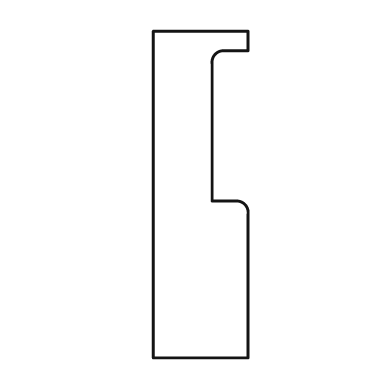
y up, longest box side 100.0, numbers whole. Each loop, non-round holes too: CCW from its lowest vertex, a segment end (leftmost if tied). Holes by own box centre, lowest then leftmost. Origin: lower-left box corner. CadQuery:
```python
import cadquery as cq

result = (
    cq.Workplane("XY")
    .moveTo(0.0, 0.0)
    .lineTo(29.0, 0.0)
    .lineTo(29.0, 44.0)
    .threePointArc((28.0, 47.0), (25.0, 48.0))
    .lineTo(18.0, 48.0)
    .lineTo(18.0, 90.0)
    .threePointArc((19.0, 93.0), (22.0, 94.0))
    .lineTo(29.0, 94.0)
    .lineTo(29.0, 100.0)
    .lineTo(0.0, 100.0)
    .close()
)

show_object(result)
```